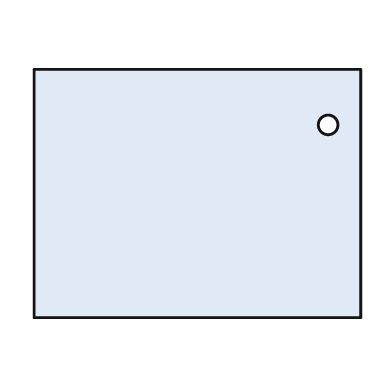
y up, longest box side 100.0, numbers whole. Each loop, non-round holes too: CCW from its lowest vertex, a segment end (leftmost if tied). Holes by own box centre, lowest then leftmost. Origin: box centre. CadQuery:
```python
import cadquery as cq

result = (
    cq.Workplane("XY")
    .moveTo(-50.0, -38.0)
    .lineTo(50.0, -38.0)
    .lineTo(50.0, 38.0)
    .lineTo(-50.0, 38.0)
    .close()
    .moveTo(40.0, 21.0)
    .circle(3.0)
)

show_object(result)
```